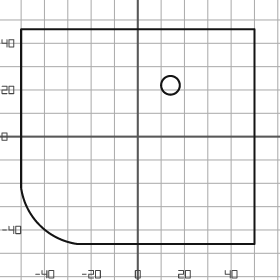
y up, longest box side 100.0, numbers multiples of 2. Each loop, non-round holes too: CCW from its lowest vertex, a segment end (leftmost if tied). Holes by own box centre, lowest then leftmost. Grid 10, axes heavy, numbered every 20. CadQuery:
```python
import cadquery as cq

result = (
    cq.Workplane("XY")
    .moveTo(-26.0, -46.0)
    .lineTo(50.0, -46.0)
    .lineTo(50.0, 46.0)
    .lineTo(-50.0, 46.0)
    .lineTo(-50.0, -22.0)
    .threePointArc((-42.0, -38.0), (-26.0, -46.0))
    .close()
    .moveTo(14.0, 22.0)
    .circle(4.0)
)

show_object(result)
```